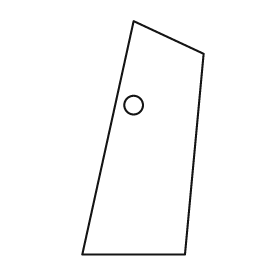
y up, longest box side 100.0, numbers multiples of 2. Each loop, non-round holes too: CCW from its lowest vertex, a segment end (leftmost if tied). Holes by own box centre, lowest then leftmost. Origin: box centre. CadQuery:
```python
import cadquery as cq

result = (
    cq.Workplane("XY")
    .moveTo(-26.0, -50.0)
    .lineTo(18.0, -50.0)
    .lineTo(26.0, 36.0)
    .lineTo(-4.0, 50.0)
    .close()
    .moveTo(-4.0, 14.0)
    .circle(4.0)
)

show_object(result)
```